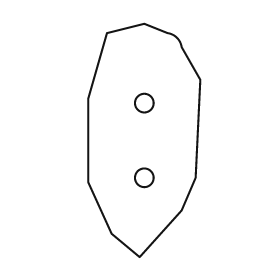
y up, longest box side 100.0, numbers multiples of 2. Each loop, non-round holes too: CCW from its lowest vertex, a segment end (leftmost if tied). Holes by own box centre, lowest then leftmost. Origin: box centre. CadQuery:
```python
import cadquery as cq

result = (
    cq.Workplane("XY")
    .moveTo(-2.0, -50.0)
    .lineTo(16.0, -30.0)
    .lineTo(22.0, -16.0)
    .lineTo(24.0, 26.0)
    .lineTo(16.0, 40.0)
    .threePointArc((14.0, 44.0), (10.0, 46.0))
    .lineTo(0.0, 50.0)
    .lineTo(-16.0, 46.0)
    .lineTo(-24.0, 18.0)
    .lineTo(-24.0, -18.0)
    .lineTo(-14.0, -40.0)
    .close()
    .moveTo(0.0, -16.0)
    .circle(4.0)
    .moveTo(0.0, 16.0)
    .circle(4.0)
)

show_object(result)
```